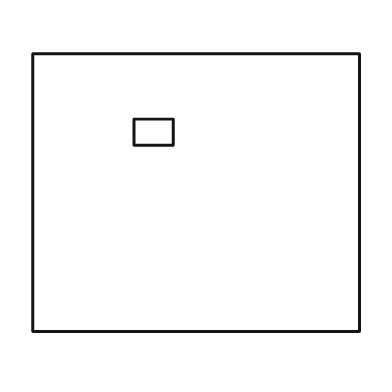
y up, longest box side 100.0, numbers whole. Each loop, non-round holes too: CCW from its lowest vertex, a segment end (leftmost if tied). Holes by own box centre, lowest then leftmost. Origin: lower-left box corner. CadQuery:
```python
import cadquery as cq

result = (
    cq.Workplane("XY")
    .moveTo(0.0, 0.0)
    .lineTo(100.0, 0.0)
    .lineTo(100.0, 85.0)
    .lineTo(0.0, 85.0)
    .close()
    .moveTo(31.0, 57.0)
    .lineTo(43.0, 57.0)
    .lineTo(43.0, 65.0)
    .lineTo(31.0, 65.0)
    .close()
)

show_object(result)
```